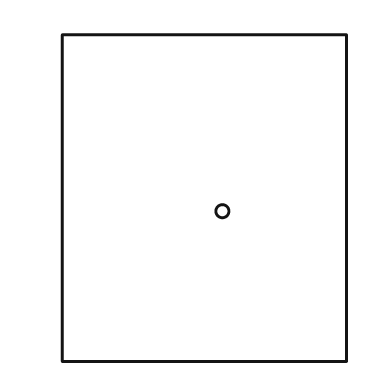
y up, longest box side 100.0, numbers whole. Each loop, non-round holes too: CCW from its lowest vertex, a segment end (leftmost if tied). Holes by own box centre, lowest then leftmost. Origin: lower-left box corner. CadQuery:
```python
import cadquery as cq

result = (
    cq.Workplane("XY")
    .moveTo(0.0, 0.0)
    .lineTo(87.0, 0.0)
    .lineTo(87.0, 100.0)
    .lineTo(0.0, 100.0)
    .close()
    .moveTo(49.0, 46.0)
    .circle(2.0)
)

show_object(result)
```